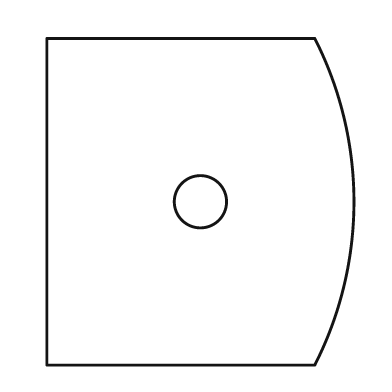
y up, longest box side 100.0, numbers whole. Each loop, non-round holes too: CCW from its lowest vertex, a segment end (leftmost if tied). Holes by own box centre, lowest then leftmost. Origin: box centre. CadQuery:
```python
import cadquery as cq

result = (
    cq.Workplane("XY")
    .moveTo(-47.0, -50.0)
    .lineTo(35.0, -50.0)
    .threePointArc((47.0, 0.0), (35.0, 50.0))
    .lineTo(-47.0, 50.0)
    .close()
    .moveTo(0.0, 0.0)
    .circle(8.0)
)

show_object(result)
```